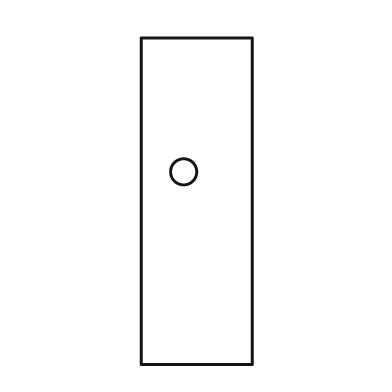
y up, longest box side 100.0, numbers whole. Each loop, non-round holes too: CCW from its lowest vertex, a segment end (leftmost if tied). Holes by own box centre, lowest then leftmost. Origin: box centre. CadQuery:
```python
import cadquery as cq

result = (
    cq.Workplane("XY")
    .moveTo(-17.0, -50.0)
    .lineTo(17.0, -50.0)
    .lineTo(17.0, 50.0)
    .lineTo(-17.0, 50.0)
    .close()
    .moveTo(-4.0, 9.0)
    .circle(4.0)
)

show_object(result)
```